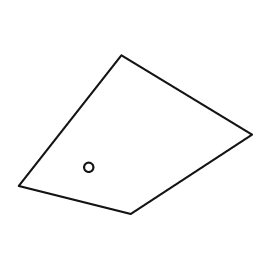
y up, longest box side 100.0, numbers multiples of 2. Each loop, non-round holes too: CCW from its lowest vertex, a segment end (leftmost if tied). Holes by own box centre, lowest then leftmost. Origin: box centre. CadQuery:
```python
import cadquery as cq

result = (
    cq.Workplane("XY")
    .moveTo(-2.0, -34.0)
    .lineTo(50.0, 0.0)
    .lineTo(-6.0, 34.0)
    .lineTo(-50.0, -22.0)
    .close()
    .moveTo(-20.0, -14.0)
    .circle(2.0)
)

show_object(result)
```